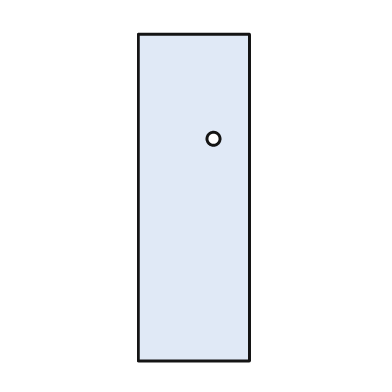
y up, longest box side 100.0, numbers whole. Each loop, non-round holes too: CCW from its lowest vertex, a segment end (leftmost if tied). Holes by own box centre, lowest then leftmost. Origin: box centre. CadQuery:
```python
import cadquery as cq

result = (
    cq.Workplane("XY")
    .moveTo(-17.0, -50.0)
    .lineTo(17.0, -50.0)
    .lineTo(17.0, 50.0)
    .lineTo(-17.0, 50.0)
    .close()
    .moveTo(6.0, 18.0)
    .circle(2.0)
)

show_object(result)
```